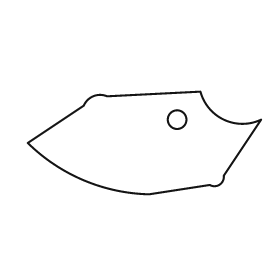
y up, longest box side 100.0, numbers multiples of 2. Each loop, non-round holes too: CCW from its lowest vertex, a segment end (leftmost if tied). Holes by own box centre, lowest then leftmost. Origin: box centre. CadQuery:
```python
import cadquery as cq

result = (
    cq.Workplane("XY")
    .moveTo(2.0, -22.0)
    .lineTo(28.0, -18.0)
    .threePointArc((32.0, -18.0), (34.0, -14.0))
    .lineTo(50.0, 10.0)
    .threePointArc((34.0, 10.0), (24.0, 22.0))
    .lineTo(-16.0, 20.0)
    .threePointArc((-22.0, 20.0), (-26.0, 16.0))
    .lineTo(-50.0, 0.0)
    .threePointArc((-26.0, -16.0), (2.0, -22.0))
    .close()
    .moveTo(14.0, 10.0)
    .circle(4.0)
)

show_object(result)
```